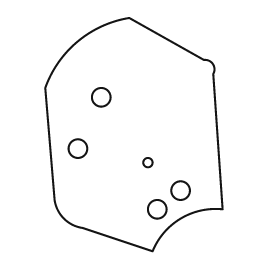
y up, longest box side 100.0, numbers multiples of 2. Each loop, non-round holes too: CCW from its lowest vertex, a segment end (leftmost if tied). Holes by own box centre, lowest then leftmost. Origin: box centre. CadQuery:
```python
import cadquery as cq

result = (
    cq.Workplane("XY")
    .moveTo(8.0, -50.0)
    .threePointArc((20.0, -36.0), (38.0, -32.0))
    .lineTo(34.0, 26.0)
    .threePointArc((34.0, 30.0), (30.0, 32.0))
    .lineTo(-2.0, 50.0)
    .threePointArc((-24.0, 40.0), (-38.0, 20.0))
    .lineTo(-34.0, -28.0)
    .threePointArc((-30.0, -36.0), (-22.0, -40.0))
    .close()
    .moveTo(10.0, -32.0)
    .circle(4.0)
    .moveTo(20.0, -24.0)
    .circle(4.0)
    .moveTo(6.0, -12.0)
    .circle(2.0)
    .moveTo(-24.0, -6.0)
    .circle(4.0)
    .moveTo(-14.0, 16.0)
    .circle(4.0)
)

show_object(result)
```